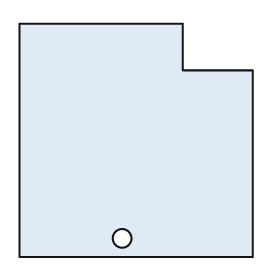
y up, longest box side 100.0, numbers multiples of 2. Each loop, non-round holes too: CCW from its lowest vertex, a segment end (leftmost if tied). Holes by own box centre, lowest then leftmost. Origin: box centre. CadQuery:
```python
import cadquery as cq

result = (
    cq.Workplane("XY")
    .moveTo(-50.0, -50.0)
    .lineTo(50.0, -50.0)
    .lineTo(50.0, 30.0)
    .lineTo(20.0, 30.0)
    .lineTo(20.0, 50.0)
    .lineTo(-50.0, 50.0)
    .close()
    .moveTo(-6.0, -42.0)
    .circle(4.0)
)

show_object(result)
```